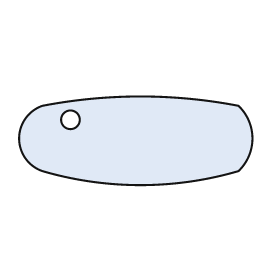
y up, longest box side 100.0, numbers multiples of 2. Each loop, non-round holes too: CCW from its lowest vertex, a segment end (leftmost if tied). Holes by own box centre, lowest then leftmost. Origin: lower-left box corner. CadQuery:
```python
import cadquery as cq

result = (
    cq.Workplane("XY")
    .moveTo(10.0, 6.0)
    .threePointArc((52.0, 0.0), (94.0, 6.0))
    .threePointArc((100.0, 20.0), (94.0, 34.0))
    .threePointArc((52.0, 38.0), (10.0, 34.0))
    .threePointArc((0.0, 20.0), (10.0, 6.0))
    .close()
    .moveTo(22.0, 28.0)
    .circle(4.0)
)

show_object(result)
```